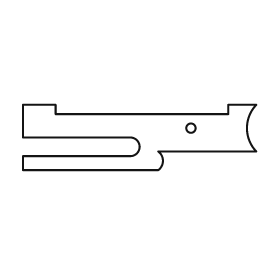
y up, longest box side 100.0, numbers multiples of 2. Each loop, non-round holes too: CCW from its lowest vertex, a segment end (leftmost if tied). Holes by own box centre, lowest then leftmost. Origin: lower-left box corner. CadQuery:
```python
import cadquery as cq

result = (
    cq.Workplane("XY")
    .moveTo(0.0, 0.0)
    .lineTo(58.0, 0.0)
    .threePointArc((60.0, 4.0), (58.0, 8.0))
    .lineTo(100.0, 8.0)
    .threePointArc((96.0, 18.0), (100.0, 28.0))
    .lineTo(88.0, 28.0)
    .lineTo(88.0, 24.0)
    .lineTo(14.0, 24.0)
    .lineTo(14.0, 28.0)
    .lineTo(0.0, 28.0)
    .lineTo(0.0, 14.0)
    .lineTo(46.0, 14.0)
    .threePointArc((50.0, 10.0), (46.0, 6.0))
    .lineTo(0.0, 6.0)
    .close()
    .moveTo(72.0, 18.0)
    .circle(2.0)
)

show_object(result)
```